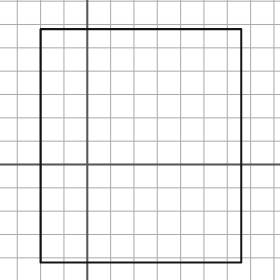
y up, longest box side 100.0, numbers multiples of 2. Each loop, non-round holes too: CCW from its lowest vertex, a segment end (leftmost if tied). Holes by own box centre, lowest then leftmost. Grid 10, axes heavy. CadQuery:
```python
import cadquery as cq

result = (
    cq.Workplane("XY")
    .moveTo(-20.0, -42.0)
    .lineTo(66.0, -42.0)
    .lineTo(66.0, 58.0)
    .lineTo(-20.0, 58.0)
    .close()
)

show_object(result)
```